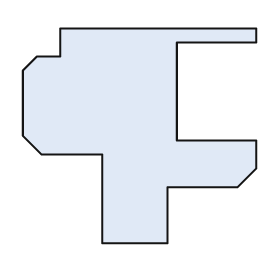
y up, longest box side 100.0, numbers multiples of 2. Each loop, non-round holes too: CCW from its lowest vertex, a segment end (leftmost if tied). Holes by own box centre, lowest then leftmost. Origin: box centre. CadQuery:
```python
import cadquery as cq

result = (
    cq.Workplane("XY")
    .moveTo(-16.0, -46.0)
    .lineTo(12.0, -46.0)
    .lineTo(12.0, -22.0)
    .lineTo(42.0, -22.0)
    .lineTo(50.0, -14.0)
    .lineTo(50.0, -2.0)
    .lineTo(16.0, -2.0)
    .lineTo(16.0, 40.0)
    .lineTo(50.0, 40.0)
    .lineTo(50.0, 46.0)
    .lineTo(-34.0, 46.0)
    .lineTo(-34.0, 34.0)
    .lineTo(-44.0, 34.0)
    .lineTo(-50.0, 28.0)
    .lineTo(-50.0, 0.0)
    .lineTo(-42.0, -8.0)
    .lineTo(-16.0, -8.0)
    .close()
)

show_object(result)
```